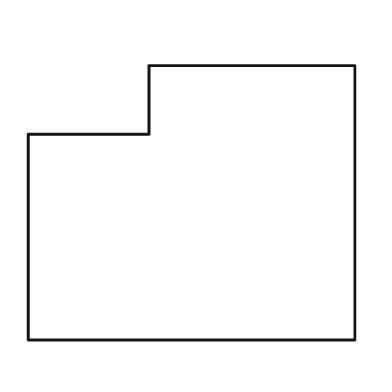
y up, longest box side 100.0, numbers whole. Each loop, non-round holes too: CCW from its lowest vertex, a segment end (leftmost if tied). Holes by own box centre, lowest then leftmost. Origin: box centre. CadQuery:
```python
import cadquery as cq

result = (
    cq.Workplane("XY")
    .moveTo(-50.0, -42.0)
    .lineTo(50.0, -42.0)
    .lineTo(50.0, 42.0)
    .lineTo(-13.0, 42.0)
    .lineTo(-13.0, 21.0)
    .lineTo(-50.0, 21.0)
    .close()
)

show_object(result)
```